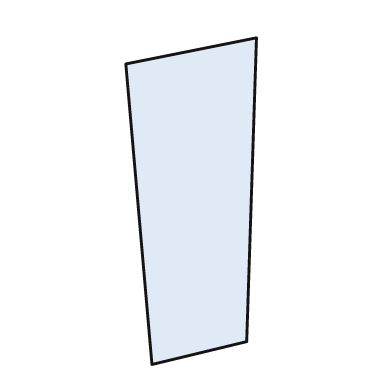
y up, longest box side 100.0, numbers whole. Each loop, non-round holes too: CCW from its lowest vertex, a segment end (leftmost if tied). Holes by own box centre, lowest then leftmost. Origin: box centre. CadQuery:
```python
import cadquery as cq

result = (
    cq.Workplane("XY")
    .moveTo(-12.0, -50.0)
    .lineTo(17.0, -43.0)
    .lineTo(20.0, 50.0)
    .lineTo(-20.0, 42.0)
    .close()
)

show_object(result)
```